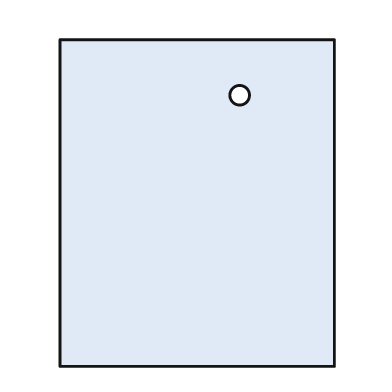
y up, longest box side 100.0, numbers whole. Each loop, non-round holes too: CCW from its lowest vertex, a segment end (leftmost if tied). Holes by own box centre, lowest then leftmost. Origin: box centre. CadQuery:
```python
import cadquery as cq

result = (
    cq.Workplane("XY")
    .moveTo(-42.0, -50.0)
    .lineTo(42.0, -50.0)
    .lineTo(42.0, 50.0)
    .lineTo(-42.0, 50.0)
    .close()
    .moveTo(13.0, 33.0)
    .circle(3.0)
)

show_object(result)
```